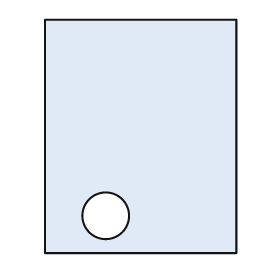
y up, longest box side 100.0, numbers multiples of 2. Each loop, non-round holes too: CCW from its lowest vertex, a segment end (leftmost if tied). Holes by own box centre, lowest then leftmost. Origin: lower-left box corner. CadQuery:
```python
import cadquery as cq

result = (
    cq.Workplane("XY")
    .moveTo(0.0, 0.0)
    .lineTo(82.0, 0.0)
    .lineTo(82.0, 100.0)
    .lineTo(0.0, 100.0)
    .close()
    .moveTo(26.0, 16.0)
    .circle(10.0)
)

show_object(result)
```